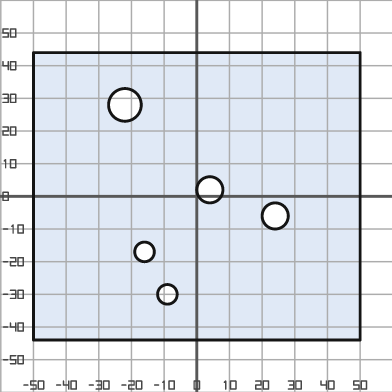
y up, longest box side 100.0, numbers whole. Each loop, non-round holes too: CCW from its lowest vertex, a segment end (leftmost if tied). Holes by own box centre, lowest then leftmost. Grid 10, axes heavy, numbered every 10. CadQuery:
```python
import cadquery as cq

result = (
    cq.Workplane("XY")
    .moveTo(-50.0, -44.0)
    .lineTo(50.0, -44.0)
    .lineTo(50.0, 44.0)
    .lineTo(-50.0, 44.0)
    .close()
    .moveTo(-9.0, -30.0)
    .circle(3.0)
    .moveTo(-16.0, -17.0)
    .circle(3.0)
    .moveTo(24.0, -6.0)
    .circle(4.0)
    .moveTo(4.0, 2.0)
    .circle(4.0)
    .moveTo(-22.0, 28.0)
    .circle(5.0)
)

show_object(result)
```